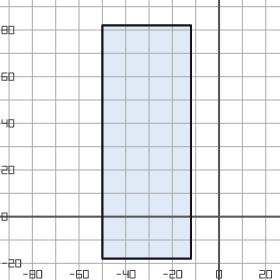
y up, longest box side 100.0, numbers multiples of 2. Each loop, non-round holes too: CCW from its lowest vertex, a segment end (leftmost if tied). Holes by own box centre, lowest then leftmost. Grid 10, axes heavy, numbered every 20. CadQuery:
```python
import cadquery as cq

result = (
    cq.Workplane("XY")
    .moveTo(-50.0, -18.0)
    .lineTo(-12.0, -18.0)
    .lineTo(-12.0, 82.0)
    .lineTo(-50.0, 82.0)
    .close()
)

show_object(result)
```